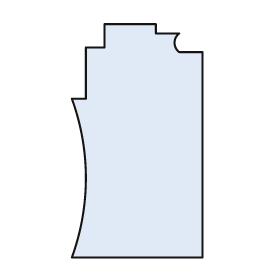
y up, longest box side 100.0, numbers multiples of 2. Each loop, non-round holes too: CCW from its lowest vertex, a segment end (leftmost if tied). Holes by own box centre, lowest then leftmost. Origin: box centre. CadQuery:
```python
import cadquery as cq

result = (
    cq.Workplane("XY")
    .moveTo(-28.0, -50.0)
    .lineTo(28.0, -50.0)
    .lineTo(28.0, 38.0)
    .lineTo(18.0, 38.0)
    .threePointArc((16.0, 42.0), (18.0, 46.0))
    .lineTo(8.0, 46.0)
    .lineTo(8.0, 50.0)
    .lineTo(-14.0, 50.0)
    .lineTo(-14.0, 40.0)
    .lineTo(-22.0, 40.0)
    .lineTo(-22.0, 18.0)
    .lineTo(-28.0, 18.0)
    .threePointArc((-22.0, -16.0), (-28.0, -50.0))
    .close()
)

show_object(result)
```